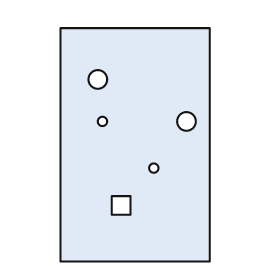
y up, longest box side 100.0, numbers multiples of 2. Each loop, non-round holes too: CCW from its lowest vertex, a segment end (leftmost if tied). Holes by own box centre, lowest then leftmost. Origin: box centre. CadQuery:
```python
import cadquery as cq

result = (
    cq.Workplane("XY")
    .moveTo(-32.0, -50.0)
    .lineTo(32.0, -50.0)
    .lineTo(32.0, 50.0)
    .lineTo(-32.0, 50.0)
    .close()
    .moveTo(-10.0, -30.0)
    .lineTo(-2.0, -30.0)
    .lineTo(-2.0, -22.0)
    .lineTo(-10.0, -22.0)
    .close()
    .moveTo(8.0, -10.0)
    .circle(2.0)
    .moveTo(-14.0, 10.0)
    .circle(2.0)
    .moveTo(22.0, 10.0)
    .circle(4.0)
    .moveTo(-16.0, 28.0)
    .circle(4.0)
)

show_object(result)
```